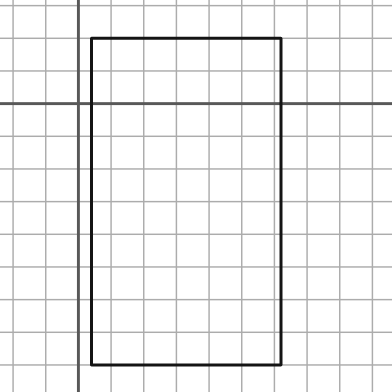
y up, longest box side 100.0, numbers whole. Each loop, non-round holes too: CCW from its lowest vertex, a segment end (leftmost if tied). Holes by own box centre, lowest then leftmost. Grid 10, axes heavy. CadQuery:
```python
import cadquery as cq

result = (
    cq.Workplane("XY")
    .moveTo(4.0, -80.0)
    .lineTo(62.0, -80.0)
    .lineTo(62.0, 20.0)
    .lineTo(4.0, 20.0)
    .close()
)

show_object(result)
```